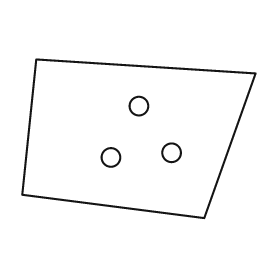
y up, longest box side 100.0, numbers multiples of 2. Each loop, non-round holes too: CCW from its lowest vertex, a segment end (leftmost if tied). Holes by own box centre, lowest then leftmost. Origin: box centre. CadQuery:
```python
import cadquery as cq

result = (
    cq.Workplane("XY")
    .moveTo(28.0, -34.0)
    .lineTo(50.0, 28.0)
    .lineTo(-44.0, 34.0)
    .lineTo(-50.0, -24.0)
    .close()
    .moveTo(-12.0, -8.0)
    .circle(4.0)
    .moveTo(14.0, -6.0)
    .circle(4.0)
    .moveTo(0.0, 14.0)
    .circle(4.0)
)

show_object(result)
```